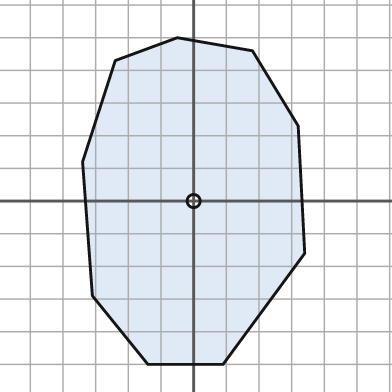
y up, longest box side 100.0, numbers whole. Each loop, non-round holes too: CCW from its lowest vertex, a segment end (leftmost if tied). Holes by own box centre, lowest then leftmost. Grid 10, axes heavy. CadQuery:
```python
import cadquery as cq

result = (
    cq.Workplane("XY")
    .moveTo(-14.0, -50.0)
    .lineTo(9.0, -50.0)
    .lineTo(34.0, -16.0)
    .lineTo(32.0, 23.0)
    .lineTo(18.0, 46.0)
    .lineTo(-5.0, 50.0)
    .lineTo(-24.0, 43.0)
    .lineTo(-34.0, 12.0)
    .lineTo(-31.0, -29.0)
    .close()
    .moveTo(0.0, 0.0)
    .circle(2.0)
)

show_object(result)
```